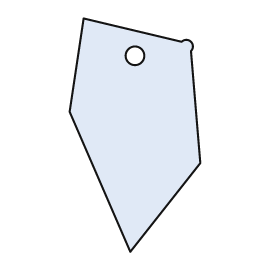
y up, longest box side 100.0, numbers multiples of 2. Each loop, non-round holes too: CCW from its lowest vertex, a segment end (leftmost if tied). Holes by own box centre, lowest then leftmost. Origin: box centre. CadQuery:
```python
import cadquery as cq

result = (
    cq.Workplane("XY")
    .moveTo(-2.0, -50.0)
    .lineTo(28.0, -12.0)
    .lineTo(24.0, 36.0)
    .threePointArc((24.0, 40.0), (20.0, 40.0))
    .lineTo(-22.0, 50.0)
    .lineTo(-28.0, 10.0)
    .close()
    .moveTo(0.0, 34.0)
    .circle(4.0)
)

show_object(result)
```